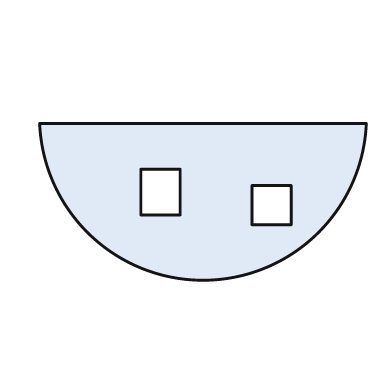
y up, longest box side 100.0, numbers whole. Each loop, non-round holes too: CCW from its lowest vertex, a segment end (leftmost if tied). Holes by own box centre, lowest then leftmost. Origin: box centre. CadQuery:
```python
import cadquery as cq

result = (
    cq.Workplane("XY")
    .moveTo(-50.0, 24.0)
    .threePointArc((0.0, -24.0), (50.0, 24.0))
    .close()
    .moveTo(15.0, -7.0)
    .lineTo(27.0, -7.0)
    .lineTo(27.0, 5.0)
    .lineTo(15.0, 5.0)
    .close()
    .moveTo(-19.0, -4.0)
    .lineTo(-7.0, -4.0)
    .lineTo(-7.0, 10.0)
    .lineTo(-19.0, 10.0)
    .close()
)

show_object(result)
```